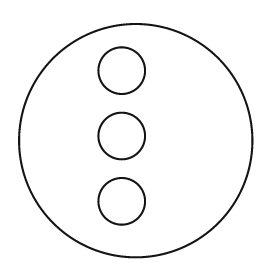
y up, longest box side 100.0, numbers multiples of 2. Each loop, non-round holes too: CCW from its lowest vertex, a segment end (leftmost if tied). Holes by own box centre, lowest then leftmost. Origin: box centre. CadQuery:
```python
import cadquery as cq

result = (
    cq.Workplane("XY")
    .moveTo(0.0, 0.0)
    .circle(50.0)
    .moveTo(-6.0, -26.0)
    .circle(10.0)
    .moveTo(-6.0, 2.0)
    .circle(10.0)
    .moveTo(-6.0, 30.0)
    .circle(10.0)
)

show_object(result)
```